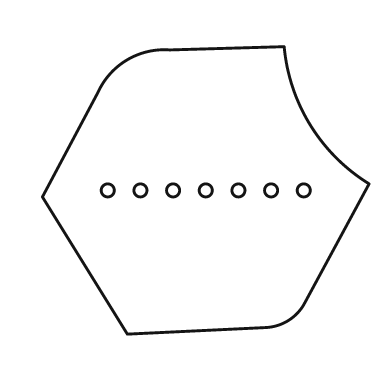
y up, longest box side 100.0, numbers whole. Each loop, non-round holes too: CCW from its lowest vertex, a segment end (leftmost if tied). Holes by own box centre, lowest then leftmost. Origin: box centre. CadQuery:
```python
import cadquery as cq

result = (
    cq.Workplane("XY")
    .moveTo(-24.0, -44.0)
    .lineTo(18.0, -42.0)
    .threePointArc((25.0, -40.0), (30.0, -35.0))
    .lineTo(50.0, 2.0)
    .threePointArc((32.0, 20.0), (24.0, 44.0))
    .lineTo(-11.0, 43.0)
    .threePointArc((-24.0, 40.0), (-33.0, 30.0))
    .lineTo(-50.0, -2.0)
    .close()
    .moveTo(-30.0, 0.0)
    .circle(2.0)
    .moveTo(-20.0, 0.0)
    .circle(2.0)
    .moveTo(-10.0, 0.0)
    .circle(2.0)
    .moveTo(0.0, 0.0)
    .circle(2.0)
    .moveTo(10.0, 0.0)
    .circle(2.0)
    .moveTo(20.0, 0.0)
    .circle(2.0)
    .moveTo(30.0, 0.0)
    .circle(2.0)
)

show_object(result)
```